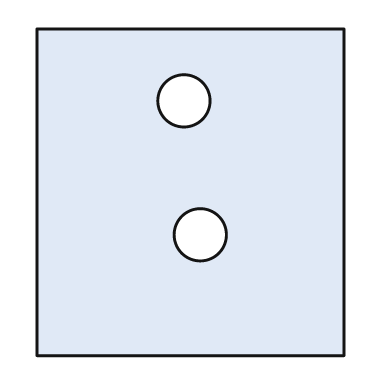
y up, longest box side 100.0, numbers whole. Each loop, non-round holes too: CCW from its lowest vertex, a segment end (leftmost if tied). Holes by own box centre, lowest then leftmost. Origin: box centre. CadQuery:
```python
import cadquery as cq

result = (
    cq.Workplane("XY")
    .moveTo(-47.0, -50.0)
    .lineTo(47.0, -50.0)
    .lineTo(47.0, 50.0)
    .lineTo(-47.0, 50.0)
    .close()
    .moveTo(3.0, -13.0)
    .circle(8.0)
    .moveTo(-2.0, 28.0)
    .circle(8.0)
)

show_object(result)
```